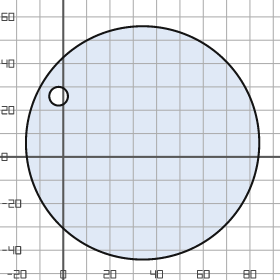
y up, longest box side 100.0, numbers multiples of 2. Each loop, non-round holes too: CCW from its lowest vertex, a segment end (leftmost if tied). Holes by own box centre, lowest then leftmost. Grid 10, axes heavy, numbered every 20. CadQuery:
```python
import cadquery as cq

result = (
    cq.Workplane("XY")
    .moveTo(34.0, 6.0)
    .circle(50.0)
    .moveTo(-2.0, 26.0)
    .circle(4.0)
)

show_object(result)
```